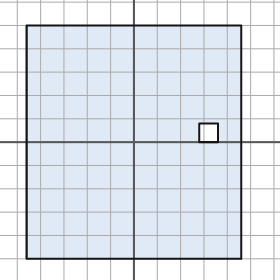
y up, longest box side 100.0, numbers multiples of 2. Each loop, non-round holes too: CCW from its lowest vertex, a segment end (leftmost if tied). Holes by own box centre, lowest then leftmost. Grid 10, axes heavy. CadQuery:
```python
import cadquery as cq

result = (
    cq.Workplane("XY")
    .moveTo(-46.0, -50.0)
    .lineTo(46.0, -50.0)
    .lineTo(46.0, 50.0)
    .lineTo(-46.0, 50.0)
    .close()
    .moveTo(28.0, 0.0)
    .lineTo(36.0, 0.0)
    .lineTo(36.0, 8.0)
    .lineTo(28.0, 8.0)
    .close()
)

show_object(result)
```